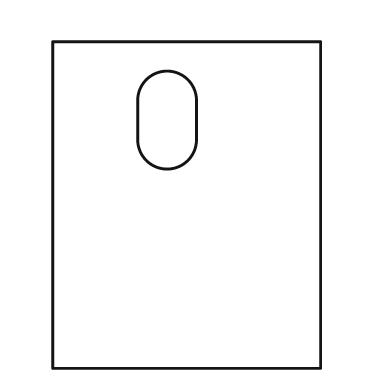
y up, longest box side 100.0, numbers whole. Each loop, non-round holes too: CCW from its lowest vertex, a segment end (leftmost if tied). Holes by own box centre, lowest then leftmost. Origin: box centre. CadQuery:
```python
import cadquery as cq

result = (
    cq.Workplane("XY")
    .moveTo(-41.0, -50.0)
    .lineTo(41.0, -50.0)
    .lineTo(41.0, 50.0)
    .lineTo(-41.0, 50.0)
    .close()
    .moveTo(-15.0, 20.0)
    .threePointArc((-6.0, 11.0), (3.0, 20.0))
    .lineTo(3.0, 32.0)
    .threePointArc((-6.0, 41.0), (-15.0, 32.0))
    .close()
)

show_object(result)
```